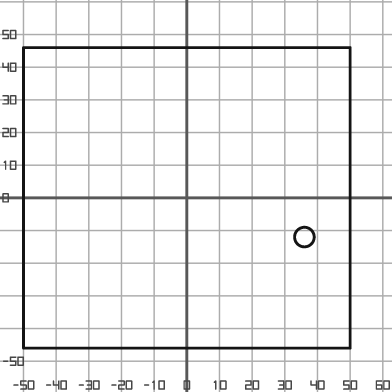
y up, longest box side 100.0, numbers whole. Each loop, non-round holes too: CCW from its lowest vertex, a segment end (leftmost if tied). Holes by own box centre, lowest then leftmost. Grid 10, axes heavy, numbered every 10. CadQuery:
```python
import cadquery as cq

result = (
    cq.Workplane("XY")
    .moveTo(-50.0, -46.0)
    .lineTo(50.0, -46.0)
    .lineTo(50.0, 46.0)
    .lineTo(-50.0, 46.0)
    .close()
    .moveTo(36.0, -12.0)
    .circle(3.0)
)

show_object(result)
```